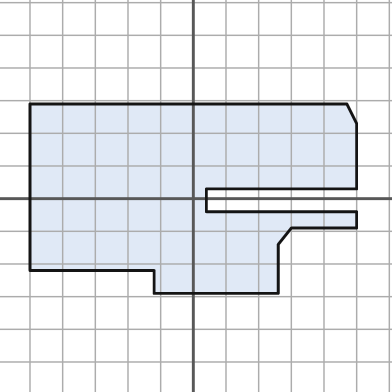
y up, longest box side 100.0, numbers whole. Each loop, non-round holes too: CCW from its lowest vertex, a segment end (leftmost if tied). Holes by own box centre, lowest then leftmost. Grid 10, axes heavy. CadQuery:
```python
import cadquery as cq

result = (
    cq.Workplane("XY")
    .moveTo(-12.0, -29.0)
    .lineTo(26.0, -29.0)
    .lineTo(26.0, -14.0)
    .lineTo(30.0, -9.0)
    .lineTo(50.0, -9.0)
    .lineTo(50.0, -4.0)
    .lineTo(4.0, -4.0)
    .lineTo(4.0, 3.0)
    .lineTo(50.0, 3.0)
    .lineTo(50.0, 23.0)
    .lineTo(47.0, 29.0)
    .lineTo(-50.0, 29.0)
    .lineTo(-50.0, -22.0)
    .lineTo(-12.0, -22.0)
    .close()
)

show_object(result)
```